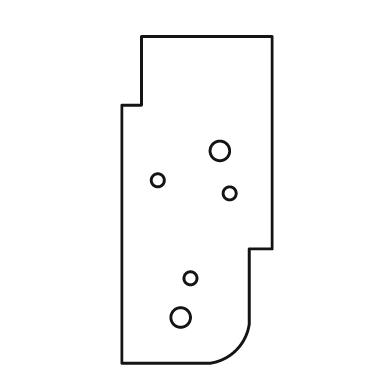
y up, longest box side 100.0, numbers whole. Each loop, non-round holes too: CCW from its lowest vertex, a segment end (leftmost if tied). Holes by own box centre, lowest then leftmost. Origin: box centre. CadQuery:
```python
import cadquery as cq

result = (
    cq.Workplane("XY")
    .moveTo(-23.0, -50.0)
    .lineTo(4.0, -50.0)
    .threePointArc((12.0, -46.0), (16.0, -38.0))
    .lineTo(16.0, -15.0)
    .lineTo(23.0, -15.0)
    .lineTo(23.0, 50.0)
    .lineTo(-17.0, 50.0)
    .lineTo(-17.0, 29.0)
    .lineTo(-23.0, 29.0)
    .close()
    .moveTo(-5.0, -36.0)
    .circle(3.0)
    .moveTo(-2.0, -24.0)
    .circle(2.0)
    .moveTo(10.0, 2.0)
    .circle(2.0)
    .moveTo(-12.0, 6.0)
    .circle(2.0)
    .moveTo(7.0, 15.0)
    .circle(3.0)
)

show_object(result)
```